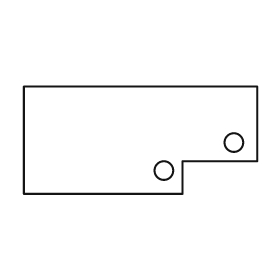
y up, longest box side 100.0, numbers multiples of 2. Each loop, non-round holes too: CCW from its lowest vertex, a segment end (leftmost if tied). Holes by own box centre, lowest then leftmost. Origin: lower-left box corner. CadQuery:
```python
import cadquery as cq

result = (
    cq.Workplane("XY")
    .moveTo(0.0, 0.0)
    .lineTo(68.0, 0.0)
    .lineTo(68.0, 14.0)
    .lineTo(100.0, 14.0)
    .lineTo(100.0, 46.0)
    .lineTo(0.0, 46.0)
    .close()
    .moveTo(60.0, 10.0)
    .circle(4.0)
    .moveTo(90.0, 22.0)
    .circle(4.0)
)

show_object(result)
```